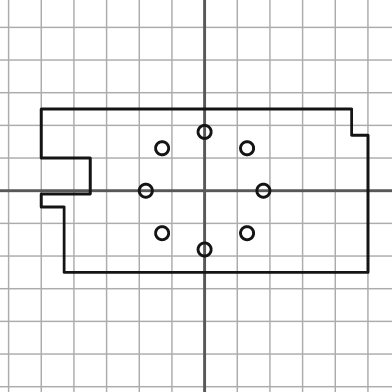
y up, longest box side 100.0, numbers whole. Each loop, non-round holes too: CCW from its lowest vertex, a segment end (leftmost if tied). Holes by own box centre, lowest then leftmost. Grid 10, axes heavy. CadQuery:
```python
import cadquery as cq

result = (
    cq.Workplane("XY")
    .moveTo(-43.0, -25.0)
    .lineTo(50.0, -25.0)
    .lineTo(50.0, 17.0)
    .lineTo(45.0, 17.0)
    .lineTo(45.0, 25.0)
    .lineTo(-50.0, 25.0)
    .lineTo(-50.0, 10.0)
    .lineTo(-35.0, 10.0)
    .lineTo(-35.0, -1.0)
    .lineTo(-50.0, -1.0)
    .lineTo(-50.0, -5.0)
    .lineTo(-43.0, -5.0)
    .close()
    .moveTo(0.0, -18.0)
    .circle(2.0)
    .moveTo(-13.0, -13.0)
    .circle(2.0)
    .moveTo(13.0, -13.0)
    .circle(2.0)
    .moveTo(-18.0, 0.0)
    .circle(2.0)
    .moveTo(18.0, 0.0)
    .circle(2.0)
    .moveTo(-13.0, 13.0)
    .circle(2.0)
    .moveTo(13.0, 13.0)
    .circle(2.0)
    .moveTo(0.0, 18.0)
    .circle(2.0)
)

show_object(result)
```